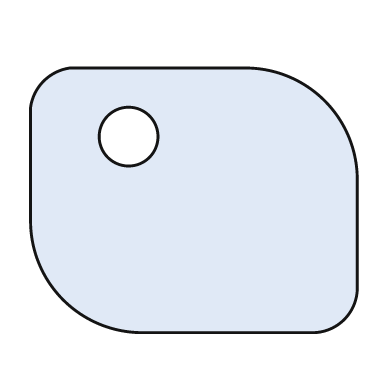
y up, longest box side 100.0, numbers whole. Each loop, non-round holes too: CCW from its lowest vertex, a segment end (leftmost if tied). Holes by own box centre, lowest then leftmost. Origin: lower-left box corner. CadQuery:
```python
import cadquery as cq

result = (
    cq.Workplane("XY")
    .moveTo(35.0, 0.0)
    .lineTo(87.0, 0.0)
    .threePointArc((96.0, 4.0), (100.0, 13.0))
    .lineTo(100.0, 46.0)
    .threePointArc((90.0, 71.0), (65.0, 81.0))
    .lineTo(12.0, 81.0)
    .threePointArc((4.0, 77.0), (0.0, 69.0))
    .lineTo(0.0, 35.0)
    .threePointArc((10.0, 10.0), (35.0, 0.0))
    .close()
    .moveTo(30.0, 60.0)
    .circle(9.0)
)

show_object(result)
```